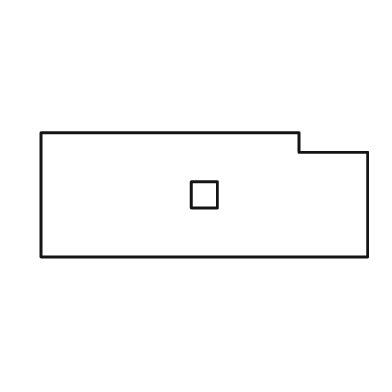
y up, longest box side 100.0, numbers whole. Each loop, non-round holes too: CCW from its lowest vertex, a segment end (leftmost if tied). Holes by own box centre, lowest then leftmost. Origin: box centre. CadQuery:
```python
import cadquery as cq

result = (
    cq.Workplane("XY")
    .moveTo(-50.0, -19.0)
    .lineTo(50.0, -19.0)
    .lineTo(50.0, 13.0)
    .lineTo(29.0, 13.0)
    .lineTo(29.0, 19.0)
    .lineTo(-50.0, 19.0)
    .close()
    .moveTo(-4.0, -4.0)
    .lineTo(4.0, -4.0)
    .lineTo(4.0, 4.0)
    .lineTo(-4.0, 4.0)
    .close()
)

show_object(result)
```